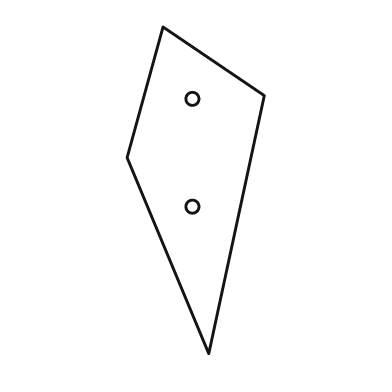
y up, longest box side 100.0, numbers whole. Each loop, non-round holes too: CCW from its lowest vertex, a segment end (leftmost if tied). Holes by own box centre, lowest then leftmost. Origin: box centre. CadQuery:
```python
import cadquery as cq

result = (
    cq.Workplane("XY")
    .moveTo(4.0, -50.0)
    .lineTo(21.0, 29.0)
    .lineTo(-10.0, 50.0)
    .lineTo(-21.0, 10.0)
    .close()
    .moveTo(-1.0, -5.0)
    .circle(2.0)
    .moveTo(-1.0, 28.0)
    .circle(2.0)
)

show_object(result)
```